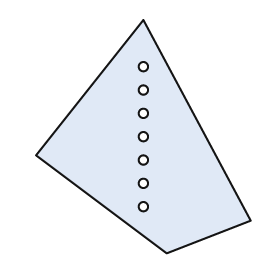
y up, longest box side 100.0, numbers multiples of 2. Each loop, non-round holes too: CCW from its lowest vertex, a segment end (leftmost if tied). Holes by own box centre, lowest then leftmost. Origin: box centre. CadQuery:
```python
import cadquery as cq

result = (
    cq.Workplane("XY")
    .moveTo(10.0, -50.0)
    .lineTo(46.0, -36.0)
    .lineTo(0.0, 50.0)
    .lineTo(-46.0, -8.0)
    .close()
    .moveTo(0.0, -30.0)
    .circle(2.0)
    .moveTo(0.0, -20.0)
    .circle(2.0)
    .moveTo(0.0, -10.0)
    .circle(2.0)
    .moveTo(0.0, 0.0)
    .circle(2.0)
    .moveTo(0.0, 10.0)
    .circle(2.0)
    .moveTo(0.0, 20.0)
    .circle(2.0)
    .moveTo(0.0, 30.0)
    .circle(2.0)
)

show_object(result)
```